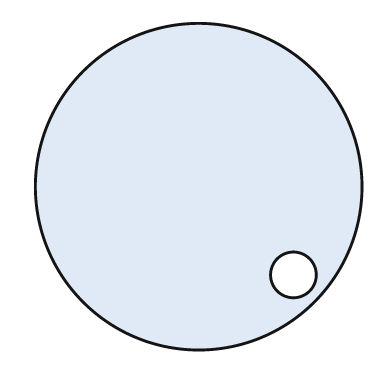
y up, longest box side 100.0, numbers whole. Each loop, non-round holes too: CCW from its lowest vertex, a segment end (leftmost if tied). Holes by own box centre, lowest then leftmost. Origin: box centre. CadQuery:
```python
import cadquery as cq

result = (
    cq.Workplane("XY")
    .moveTo(0.0, 0.0)
    .circle(50.0)
    .moveTo(29.0, -27.0)
    .circle(7.0)
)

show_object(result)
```